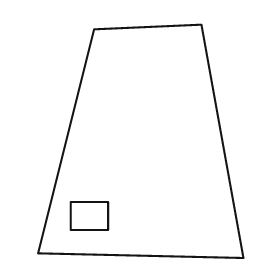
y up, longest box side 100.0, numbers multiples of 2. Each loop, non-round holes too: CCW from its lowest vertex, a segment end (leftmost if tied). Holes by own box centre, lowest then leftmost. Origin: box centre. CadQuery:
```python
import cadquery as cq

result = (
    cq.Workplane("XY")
    .moveTo(44.0, -50.0)
    .lineTo(26.0, 50.0)
    .lineTo(-20.0, 48.0)
    .lineTo(-44.0, -48.0)
    .close()
    .moveTo(-30.0, -38.0)
    .lineTo(-14.0, -38.0)
    .lineTo(-14.0, -26.0)
    .lineTo(-30.0, -26.0)
    .close()
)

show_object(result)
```